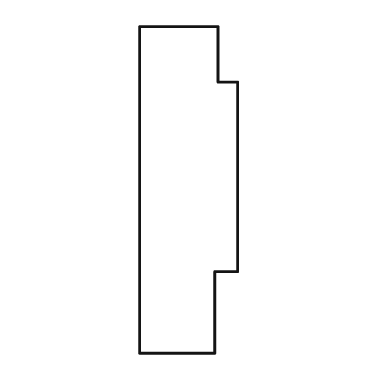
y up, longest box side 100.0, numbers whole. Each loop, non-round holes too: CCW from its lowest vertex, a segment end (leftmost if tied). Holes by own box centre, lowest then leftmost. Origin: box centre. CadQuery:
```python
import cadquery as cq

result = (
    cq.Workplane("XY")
    .moveTo(-15.0, -50.0)
    .lineTo(8.0, -50.0)
    .lineTo(8.0, -25.0)
    .lineTo(15.0, -25.0)
    .lineTo(15.0, 33.0)
    .lineTo(9.0, 33.0)
    .lineTo(9.0, 50.0)
    .lineTo(-15.0, 50.0)
    .close()
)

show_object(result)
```